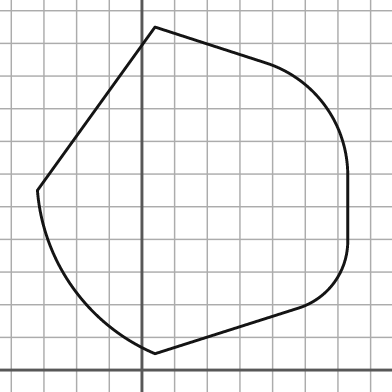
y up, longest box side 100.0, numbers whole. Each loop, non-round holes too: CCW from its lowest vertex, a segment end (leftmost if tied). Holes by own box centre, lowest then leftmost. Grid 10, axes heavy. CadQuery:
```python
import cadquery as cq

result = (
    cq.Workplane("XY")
    .moveTo(4.0, 5.0)
    .lineTo(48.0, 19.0)
    .threePointArc((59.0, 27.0), (63.0, 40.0))
    .lineTo(63.0, 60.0)
    .threePointArc((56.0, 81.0), (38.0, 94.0))
    .lineTo(4.0, 105.0)
    .lineTo(-32.0, 55.0)
    .threePointArc((-21.0, 25.0), (4.0, 5.0))
    .close()
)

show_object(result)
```